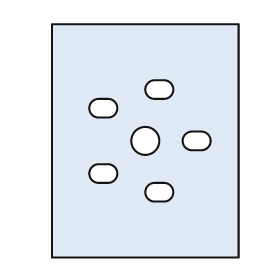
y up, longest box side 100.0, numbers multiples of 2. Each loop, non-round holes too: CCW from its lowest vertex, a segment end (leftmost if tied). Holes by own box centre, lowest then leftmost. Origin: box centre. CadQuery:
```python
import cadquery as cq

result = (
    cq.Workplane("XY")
    .moveTo(-40.0, -50.0)
    .lineTo(40.0, -50.0)
    .lineTo(40.0, 50.0)
    .lineTo(-40.0, 50.0)
    .close()
    .moveTo(4.0, -26.0)
    .lineTo(8.0, -26.0)
    .threePointArc((12.0, -22.0), (8.0, -18.0))
    .lineTo(4.0, -18.0)
    .threePointArc((0.0, -22.0), (4.0, -26.0))
    .close()
    .moveTo(-20.0, -18.0)
    .lineTo(-16.0, -18.0)
    .threePointArc((-12.0, -14.0), (-16.0, -10.0))
    .lineTo(-20.0, -10.0)
    .threePointArc((-24.0, -14.0), (-20.0, -18.0))
    .close()
    .moveTo(0.0, 0.0)
    .circle(6.0)
    .moveTo(20.0, -4.0)
    .lineTo(24.0, -4.0)
    .threePointArc((28.0, 0.0), (24.0, 4.0))
    .lineTo(20.0, 4.0)
    .threePointArc((16.0, 0.0), (20.0, -4.0))
    .close()
    .moveTo(-20.0, 10.0)
    .lineTo(-16.0, 10.0)
    .threePointArc((-12.0, 14.0), (-16.0, 18.0))
    .lineTo(-20.0, 18.0)
    .threePointArc((-24.0, 14.0), (-20.0, 10.0))
    .close()
    .moveTo(4.0, 18.0)
    .lineTo(8.0, 18.0)
    .threePointArc((12.0, 22.0), (8.0, 26.0))
    .lineTo(4.0, 26.0)
    .threePointArc((0.0, 22.0), (4.0, 18.0))
    .close()
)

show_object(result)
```